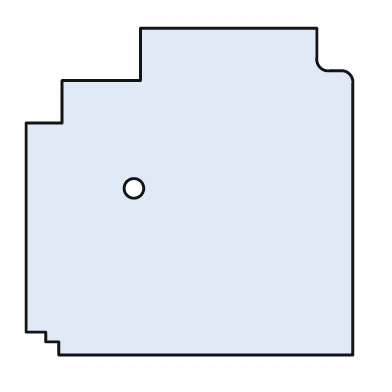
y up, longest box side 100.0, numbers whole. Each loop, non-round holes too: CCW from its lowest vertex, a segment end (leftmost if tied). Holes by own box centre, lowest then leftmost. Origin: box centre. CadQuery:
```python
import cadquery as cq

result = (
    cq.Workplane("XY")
    .moveTo(-40.0, -50.0)
    .lineTo(50.0, -50.0)
    .lineTo(50.0, 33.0)
    .threePointArc((49.0, 36.0), (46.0, 37.0))
    .lineTo(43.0, 37.0)
    .threePointArc((40.0, 38.0), (39.0, 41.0))
    .lineTo(39.0, 50.0)
    .lineTo(-15.0, 50.0)
    .lineTo(-15.0, 34.0)
    .lineTo(-39.0, 34.0)
    .lineTo(-39.0, 21.0)
    .lineTo(-50.0, 21.0)
    .lineTo(-50.0, -43.0)
    .lineTo(-44.0, -43.0)
    .lineTo(-44.0, -46.0)
    .lineTo(-40.0, -46.0)
    .close()
    .moveTo(-17.0, 1.0)
    .circle(3.0)
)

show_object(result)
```